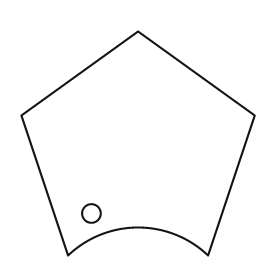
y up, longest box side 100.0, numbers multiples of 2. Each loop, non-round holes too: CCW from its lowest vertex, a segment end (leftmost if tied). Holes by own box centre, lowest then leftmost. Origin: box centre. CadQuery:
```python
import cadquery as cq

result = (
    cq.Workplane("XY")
    .moveTo(-30.0, -48.0)
    .threePointArc((0.0, -36.0), (30.0, -48.0))
    .lineTo(50.0, 12.0)
    .lineTo(0.0, 48.0)
    .lineTo(-50.0, 12.0)
    .close()
    .moveTo(-20.0, -30.0)
    .circle(4.0)
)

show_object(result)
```